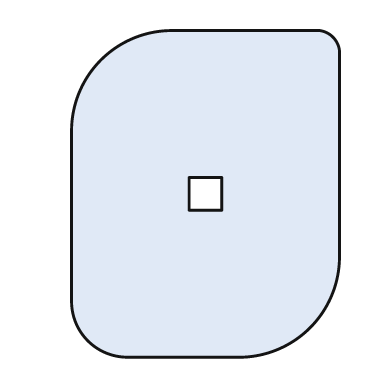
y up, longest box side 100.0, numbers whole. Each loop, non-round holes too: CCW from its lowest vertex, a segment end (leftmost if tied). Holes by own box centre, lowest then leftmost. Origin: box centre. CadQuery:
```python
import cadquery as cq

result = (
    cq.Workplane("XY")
    .moveTo(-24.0, -50.0)
    .lineTo(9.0, -50.0)
    .threePointArc((32.0, -41.0), (41.0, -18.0))
    .lineTo(41.0, 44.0)
    .threePointArc((39.0, 48.0), (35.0, 50.0))
    .lineTo(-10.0, 50.0)
    .threePointArc((-32.0, 41.0), (-41.0, 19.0))
    .lineTo(-41.0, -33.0)
    .threePointArc((-36.0, -45.0), (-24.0, -50.0))
    .close()
    .moveTo(-5.0, -5.0)
    .lineTo(5.0, -5.0)
    .lineTo(5.0, 5.0)
    .lineTo(-5.0, 5.0)
    .close()
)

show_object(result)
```